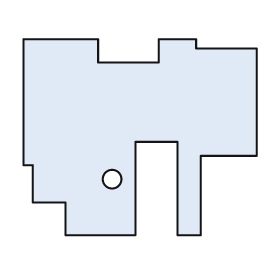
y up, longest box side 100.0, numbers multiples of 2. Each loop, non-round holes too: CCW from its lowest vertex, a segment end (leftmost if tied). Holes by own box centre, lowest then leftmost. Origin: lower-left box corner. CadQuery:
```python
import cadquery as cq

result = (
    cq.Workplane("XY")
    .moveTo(18.0, 0.0)
    .lineTo(48.0, 0.0)
    .lineTo(48.0, 40.0)
    .lineTo(66.0, 40.0)
    .lineTo(66.0, 0.0)
    .lineTo(76.0, 0.0)
    .lineTo(76.0, 34.0)
    .lineTo(100.0, 34.0)
    .lineTo(100.0, 80.0)
    .lineTo(74.0, 80.0)
    .lineTo(74.0, 84.0)
    .lineTo(58.0, 84.0)
    .lineTo(58.0, 74.0)
    .lineTo(32.0, 74.0)
    .lineTo(32.0, 84.0)
    .lineTo(0.0, 84.0)
    .lineTo(0.0, 30.0)
    .lineTo(4.0, 30.0)
    .lineTo(4.0, 14.0)
    .lineTo(18.0, 14.0)
    .close()
    .moveTo(38.0, 24.0)
    .circle(4.0)
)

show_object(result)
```